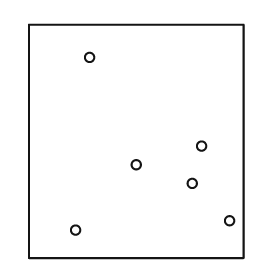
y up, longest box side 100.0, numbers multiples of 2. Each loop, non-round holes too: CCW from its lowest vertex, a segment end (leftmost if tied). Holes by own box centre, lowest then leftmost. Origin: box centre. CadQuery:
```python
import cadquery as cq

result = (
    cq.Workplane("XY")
    .moveTo(-46.0, -50.0)
    .lineTo(46.0, -50.0)
    .lineTo(46.0, 50.0)
    .lineTo(-46.0, 50.0)
    .close()
    .moveTo(-26.0, -38.0)
    .circle(2.0)
    .moveTo(40.0, -34.0)
    .circle(2.0)
    .moveTo(24.0, -18.0)
    .circle(2.0)
    .moveTo(0.0, -10.0)
    .circle(2.0)
    .moveTo(28.0, -2.0)
    .circle(2.0)
    .moveTo(-20.0, 36.0)
    .circle(2.0)
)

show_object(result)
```